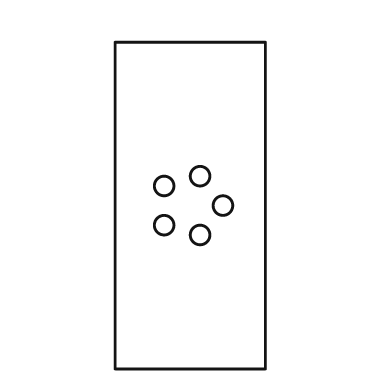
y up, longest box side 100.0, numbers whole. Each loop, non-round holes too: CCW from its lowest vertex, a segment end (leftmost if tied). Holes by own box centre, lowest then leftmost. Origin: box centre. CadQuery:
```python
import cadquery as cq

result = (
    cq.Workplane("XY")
    .moveTo(-23.0, -50.0)
    .lineTo(23.0, -50.0)
    .lineTo(23.0, 50.0)
    .lineTo(-23.0, 50.0)
    .close()
    .moveTo(3.0, -9.0)
    .circle(3.0)
    .moveTo(-8.0, -6.0)
    .circle(3.0)
    .moveTo(10.0, 0.0)
    .circle(3.0)
    .moveTo(-8.0, 6.0)
    .circle(3.0)
    .moveTo(3.0, 9.0)
    .circle(3.0)
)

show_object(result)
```